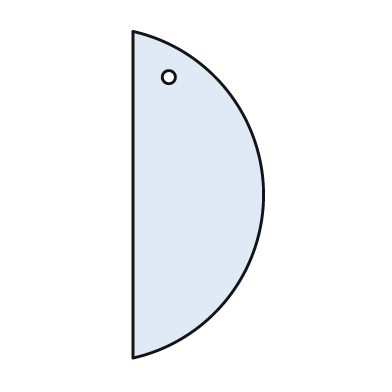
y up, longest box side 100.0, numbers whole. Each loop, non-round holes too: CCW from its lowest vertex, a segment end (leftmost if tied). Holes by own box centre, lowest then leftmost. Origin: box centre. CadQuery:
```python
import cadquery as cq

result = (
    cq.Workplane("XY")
    .moveTo(-20.0, -50.0)
    .threePointArc((20.0, 0.0), (-20.0, 50.0))
    .close()
    .moveTo(-9.0, 36.0)
    .circle(2.0)
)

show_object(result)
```